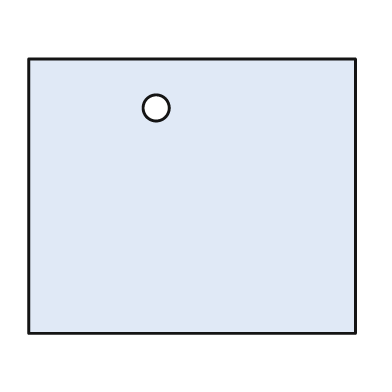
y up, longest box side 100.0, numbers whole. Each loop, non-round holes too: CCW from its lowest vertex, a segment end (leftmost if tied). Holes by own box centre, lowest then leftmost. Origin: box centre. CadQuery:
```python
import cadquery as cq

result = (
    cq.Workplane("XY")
    .moveTo(-50.0, -42.0)
    .lineTo(50.0, -42.0)
    .lineTo(50.0, 42.0)
    .lineTo(-50.0, 42.0)
    .close()
    .moveTo(-11.0, 27.0)
    .circle(4.0)
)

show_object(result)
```